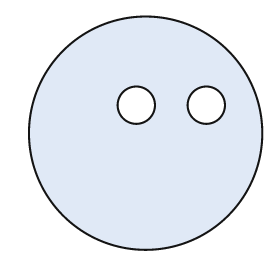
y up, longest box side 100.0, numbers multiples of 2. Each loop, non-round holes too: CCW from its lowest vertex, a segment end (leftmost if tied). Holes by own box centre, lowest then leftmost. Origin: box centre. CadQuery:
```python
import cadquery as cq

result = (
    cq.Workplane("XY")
    .moveTo(0.0, 0.0)
    .circle(50.0)
    .moveTo(-4.0, 12.0)
    .circle(8.0)
    .moveTo(26.0, 12.0)
    .circle(8.0)
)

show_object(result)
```